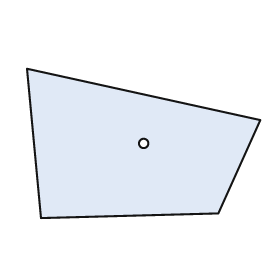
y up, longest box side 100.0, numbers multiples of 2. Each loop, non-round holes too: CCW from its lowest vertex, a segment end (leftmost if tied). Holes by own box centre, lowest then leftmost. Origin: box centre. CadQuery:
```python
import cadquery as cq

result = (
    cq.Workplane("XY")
    .moveTo(-44.0, -32.0)
    .lineTo(32.0, -30.0)
    .lineTo(50.0, 10.0)
    .lineTo(-50.0, 32.0)
    .close()
    .moveTo(0.0, 0.0)
    .circle(2.0)
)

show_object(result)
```